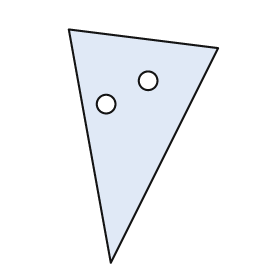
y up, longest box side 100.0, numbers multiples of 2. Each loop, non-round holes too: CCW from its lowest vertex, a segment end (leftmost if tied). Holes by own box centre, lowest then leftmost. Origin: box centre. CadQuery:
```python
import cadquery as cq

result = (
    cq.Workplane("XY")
    .moveTo(-14.0, -50.0)
    .lineTo(32.0, 42.0)
    .lineTo(-32.0, 50.0)
    .close()
    .moveTo(-16.0, 18.0)
    .circle(4.0)
    .moveTo(2.0, 28.0)
    .circle(4.0)
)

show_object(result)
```